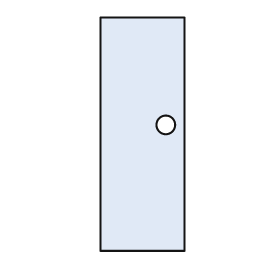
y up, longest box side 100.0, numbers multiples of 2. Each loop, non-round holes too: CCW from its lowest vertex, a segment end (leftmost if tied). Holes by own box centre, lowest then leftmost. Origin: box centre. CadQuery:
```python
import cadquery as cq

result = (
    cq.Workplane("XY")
    .moveTo(-18.0, -50.0)
    .lineTo(18.0, -50.0)
    .lineTo(18.0, 50.0)
    .lineTo(-18.0, 50.0)
    .close()
    .moveTo(10.0, 4.0)
    .circle(4.0)
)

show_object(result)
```